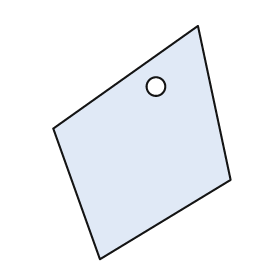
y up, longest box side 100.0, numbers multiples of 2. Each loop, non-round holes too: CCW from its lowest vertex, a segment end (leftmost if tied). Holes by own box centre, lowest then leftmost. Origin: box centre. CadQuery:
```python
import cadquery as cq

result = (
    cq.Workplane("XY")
    .moveTo(-18.0, -50.0)
    .lineTo(38.0, -16.0)
    .lineTo(24.0, 50.0)
    .lineTo(-38.0, 6.0)
    .close()
    .moveTo(6.0, 24.0)
    .circle(4.0)
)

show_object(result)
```